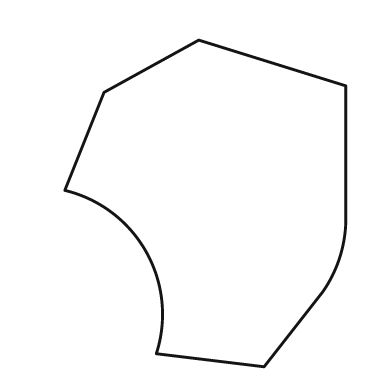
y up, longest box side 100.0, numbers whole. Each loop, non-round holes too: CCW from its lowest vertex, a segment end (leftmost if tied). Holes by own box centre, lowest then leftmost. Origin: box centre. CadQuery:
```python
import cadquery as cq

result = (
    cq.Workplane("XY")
    .moveTo(18.0, -50.0)
    .lineTo(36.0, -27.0)
    .threePointArc((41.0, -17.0), (43.0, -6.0))
    .lineTo(43.0, 36.0)
    .lineTo(-2.0, 50.0)
    .lineTo(-31.0, 34.0)
    .lineTo(-43.0, 4.0)
    .threePointArc((-18.0, -15.0), (-15.0, -46.0))
    .close()
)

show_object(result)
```